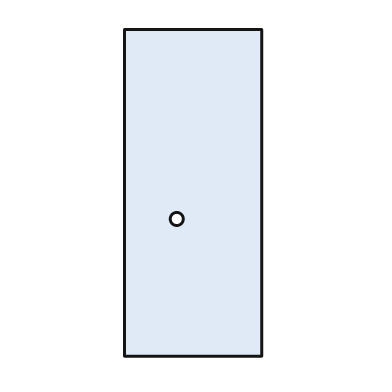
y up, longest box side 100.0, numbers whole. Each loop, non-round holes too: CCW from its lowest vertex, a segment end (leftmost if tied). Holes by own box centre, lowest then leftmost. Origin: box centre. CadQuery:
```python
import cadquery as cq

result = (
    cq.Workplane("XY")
    .moveTo(-21.0, -50.0)
    .lineTo(21.0, -50.0)
    .lineTo(21.0, 50.0)
    .lineTo(-21.0, 50.0)
    .close()
    .moveTo(-5.0, -8.0)
    .circle(2.0)
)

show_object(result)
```